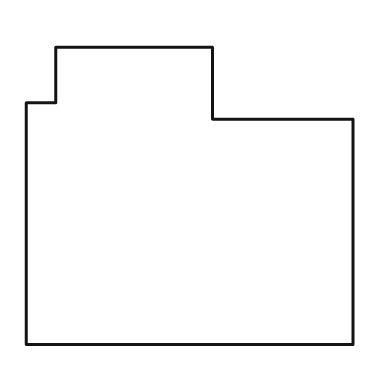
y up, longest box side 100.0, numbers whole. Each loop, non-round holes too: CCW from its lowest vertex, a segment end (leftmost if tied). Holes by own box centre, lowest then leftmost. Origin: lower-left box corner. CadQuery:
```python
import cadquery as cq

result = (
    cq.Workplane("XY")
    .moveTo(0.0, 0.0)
    .lineTo(100.0, 0.0)
    .lineTo(100.0, 69.0)
    .lineTo(57.0, 69.0)
    .lineTo(57.0, 91.0)
    .lineTo(9.0, 91.0)
    .lineTo(9.0, 74.0)
    .lineTo(0.0, 74.0)
    .close()
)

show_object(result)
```